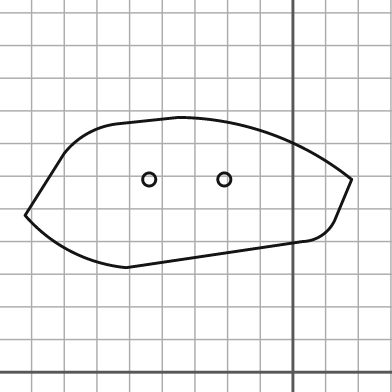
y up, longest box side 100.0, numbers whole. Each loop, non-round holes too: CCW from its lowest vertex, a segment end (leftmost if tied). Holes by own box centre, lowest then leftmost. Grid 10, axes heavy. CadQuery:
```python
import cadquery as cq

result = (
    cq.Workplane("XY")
    .moveTo(-51.0, 32.0)
    .lineTo(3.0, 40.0)
    .threePointArc((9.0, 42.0), (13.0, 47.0))
    .lineTo(18.0, 59.0)
    .threePointArc((-7.0, 73.0), (-35.0, 78.0))
    .lineTo(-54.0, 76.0)
    .threePointArc((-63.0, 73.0), (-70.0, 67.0))
    .lineTo(-82.0, 48.0)
    .threePointArc((-68.0, 37.0), (-51.0, 32.0))
    .close()
    .moveTo(-44.0, 59.0)
    .circle(2.0)
    .moveTo(-21.0, 59.0)
    .circle(2.0)
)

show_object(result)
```